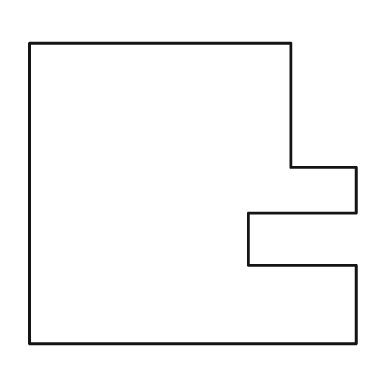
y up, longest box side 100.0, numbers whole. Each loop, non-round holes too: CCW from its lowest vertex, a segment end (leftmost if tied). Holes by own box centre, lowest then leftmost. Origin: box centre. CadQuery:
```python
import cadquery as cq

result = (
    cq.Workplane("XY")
    .moveTo(-50.0, -46.0)
    .lineTo(50.0, -46.0)
    .lineTo(50.0, -22.0)
    .lineTo(17.0, -22.0)
    .lineTo(17.0, -6.0)
    .lineTo(50.0, -6.0)
    .lineTo(50.0, 8.0)
    .lineTo(30.0, 8.0)
    .lineTo(30.0, 46.0)
    .lineTo(-50.0, 46.0)
    .close()
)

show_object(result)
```